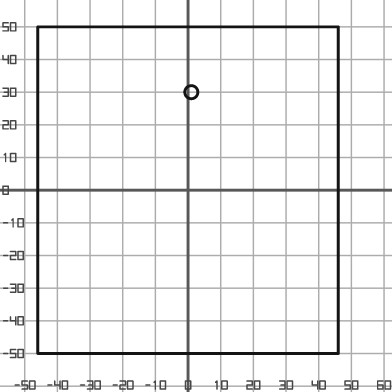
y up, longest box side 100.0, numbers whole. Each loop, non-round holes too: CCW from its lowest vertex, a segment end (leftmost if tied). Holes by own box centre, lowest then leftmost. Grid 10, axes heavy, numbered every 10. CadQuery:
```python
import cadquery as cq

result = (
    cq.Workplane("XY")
    .moveTo(-46.0, -50.0)
    .lineTo(46.0, -50.0)
    .lineTo(46.0, 50.0)
    .lineTo(-46.0, 50.0)
    .close()
    .moveTo(1.0, 30.0)
    .circle(2.0)
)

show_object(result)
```